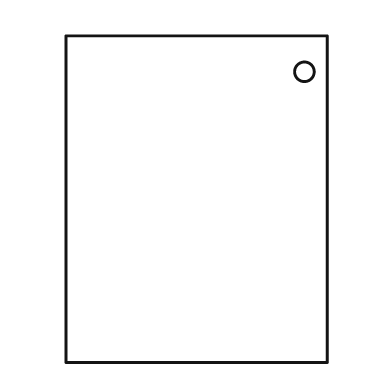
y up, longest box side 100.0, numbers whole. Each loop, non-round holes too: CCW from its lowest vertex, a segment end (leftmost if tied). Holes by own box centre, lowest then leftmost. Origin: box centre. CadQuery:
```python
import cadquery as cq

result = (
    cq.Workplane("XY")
    .moveTo(-40.0, -50.0)
    .lineTo(40.0, -50.0)
    .lineTo(40.0, 50.0)
    .lineTo(-40.0, 50.0)
    .close()
    .moveTo(33.0, 39.0)
    .circle(3.0)
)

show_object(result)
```